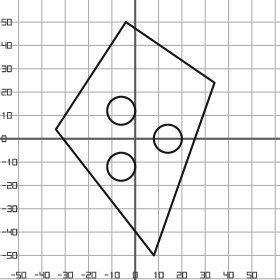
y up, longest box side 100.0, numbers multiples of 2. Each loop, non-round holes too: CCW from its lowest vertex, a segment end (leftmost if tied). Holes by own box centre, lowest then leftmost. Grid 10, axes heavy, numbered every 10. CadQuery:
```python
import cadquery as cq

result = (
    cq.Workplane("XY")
    .moveTo(8.0, -50.0)
    .lineTo(34.0, 24.0)
    .lineTo(-4.0, 50.0)
    .lineTo(-34.0, 4.0)
    .close()
    .moveTo(-6.0, -12.0)
    .circle(6.0)
    .moveTo(14.0, 0.0)
    .circle(6.0)
    .moveTo(-6.0, 12.0)
    .circle(6.0)
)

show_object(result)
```